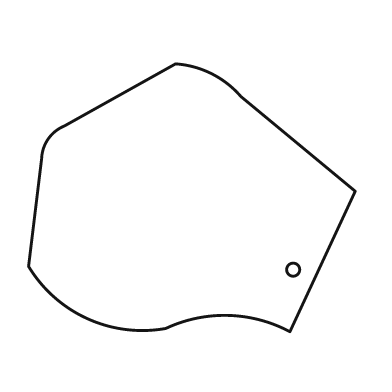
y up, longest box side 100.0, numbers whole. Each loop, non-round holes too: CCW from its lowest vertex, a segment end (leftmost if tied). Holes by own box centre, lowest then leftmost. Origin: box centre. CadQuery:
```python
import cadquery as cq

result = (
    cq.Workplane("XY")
    .moveTo(30.0, -41.0)
    .lineTo(50.0, 2.0)
    .lineTo(15.0, 31.0)
    .threePointArc((6.0, 38.0), (-5.0, 41.0))
    .lineTo(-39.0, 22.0)
    .threePointArc((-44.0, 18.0), (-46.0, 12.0))
    .lineTo(-50.0, -21.0)
    .threePointArc((-32.0, -37.0), (-8.0, -40.0))
    .threePointArc((11.0, -36.0), (30.0, -41.0))
    .close()
    .moveTo(31.0, -22.0)
    .circle(2.0)
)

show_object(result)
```